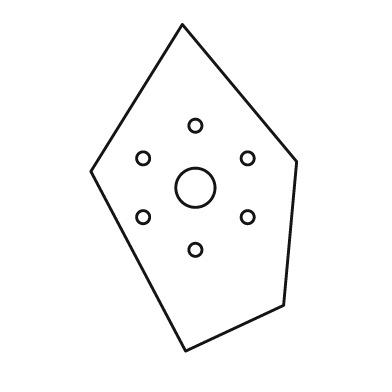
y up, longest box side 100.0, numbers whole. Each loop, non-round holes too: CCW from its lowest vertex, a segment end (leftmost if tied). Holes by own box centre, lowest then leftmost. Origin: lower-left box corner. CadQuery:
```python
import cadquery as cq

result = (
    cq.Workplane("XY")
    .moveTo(29.0, 0.0)
    .lineTo(59.0, 14.0)
    .lineTo(63.0, 58.0)
    .lineTo(28.0, 100.0)
    .lineTo(0.0, 55.0)
    .close()
    .moveTo(32.0, 31.0)
    .circle(2.0)
    .moveTo(16.0, 41.0)
    .circle(2.0)
    .moveTo(48.0, 41.0)
    .circle(2.0)
    .moveTo(32.0, 50.0)
    .circle(6.0)
    .moveTo(16.0, 59.0)
    .circle(2.0)
    .moveTo(48.0, 59.0)
    .circle(2.0)
    .moveTo(32.0, 69.0)
    .circle(2.0)
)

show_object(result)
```